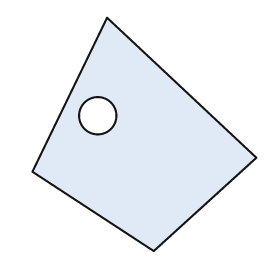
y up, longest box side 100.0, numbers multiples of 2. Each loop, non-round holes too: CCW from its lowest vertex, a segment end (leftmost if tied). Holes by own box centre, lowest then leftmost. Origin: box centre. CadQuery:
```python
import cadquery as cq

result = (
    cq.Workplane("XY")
    .moveTo(4.0, -50.0)
    .lineTo(48.0, -10.0)
    .lineTo(-16.0, 50.0)
    .lineTo(-48.0, -16.0)
    .close()
    .moveTo(-20.0, 8.0)
    .circle(8.0)
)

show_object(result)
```